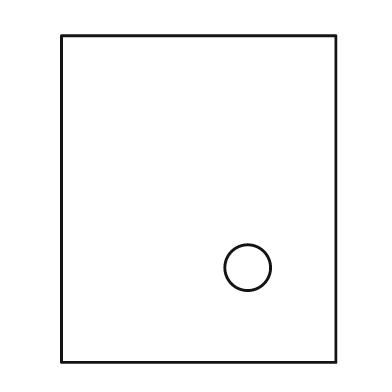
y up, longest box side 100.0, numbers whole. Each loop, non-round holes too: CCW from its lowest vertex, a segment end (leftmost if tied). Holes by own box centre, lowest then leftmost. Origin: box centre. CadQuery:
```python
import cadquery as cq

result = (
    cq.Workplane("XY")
    .moveTo(-42.0, -50.0)
    .lineTo(42.0, -50.0)
    .lineTo(42.0, 50.0)
    .lineTo(-42.0, 50.0)
    .close()
    .moveTo(15.0, -21.0)
    .circle(7.0)
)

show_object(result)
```